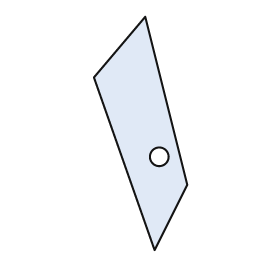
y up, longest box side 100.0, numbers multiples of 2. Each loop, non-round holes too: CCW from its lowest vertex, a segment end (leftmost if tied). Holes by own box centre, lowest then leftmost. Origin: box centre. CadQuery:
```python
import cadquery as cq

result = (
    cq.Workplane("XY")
    .moveTo(6.0, -50.0)
    .lineTo(20.0, -22.0)
    .lineTo(2.0, 50.0)
    .lineTo(-20.0, 24.0)
    .close()
    .moveTo(8.0, -10.0)
    .circle(4.0)
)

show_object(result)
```